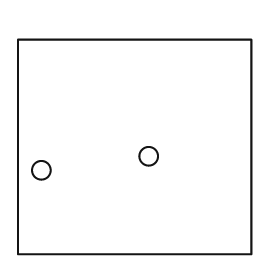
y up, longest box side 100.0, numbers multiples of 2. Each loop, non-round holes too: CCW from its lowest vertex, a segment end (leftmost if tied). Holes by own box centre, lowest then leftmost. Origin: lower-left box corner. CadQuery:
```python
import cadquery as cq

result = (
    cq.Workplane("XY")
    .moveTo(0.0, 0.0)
    .lineTo(100.0, 0.0)
    .lineTo(100.0, 92.0)
    .lineTo(0.0, 92.0)
    .close()
    .moveTo(10.0, 36.0)
    .circle(4.0)
    .moveTo(56.0, 42.0)
    .circle(4.0)
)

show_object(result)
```